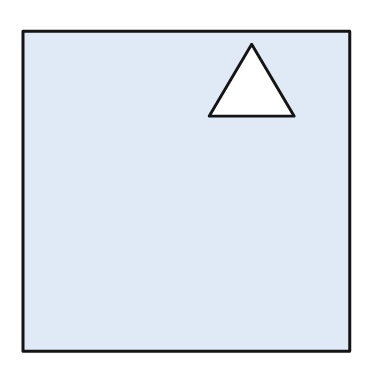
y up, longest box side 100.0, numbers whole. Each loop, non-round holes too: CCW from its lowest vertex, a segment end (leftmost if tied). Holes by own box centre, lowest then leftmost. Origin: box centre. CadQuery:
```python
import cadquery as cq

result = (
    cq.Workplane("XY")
    .moveTo(-50.0, -49.0)
    .lineTo(50.0, -49.0)
    .lineTo(50.0, 49.0)
    .lineTo(-50.0, 49.0)
    .close()
    .moveTo(7.0, 23.0)
    .lineTo(33.0, 23.0)
    .lineTo(20.0, 45.0)
    .close()
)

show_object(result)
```